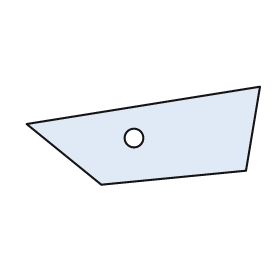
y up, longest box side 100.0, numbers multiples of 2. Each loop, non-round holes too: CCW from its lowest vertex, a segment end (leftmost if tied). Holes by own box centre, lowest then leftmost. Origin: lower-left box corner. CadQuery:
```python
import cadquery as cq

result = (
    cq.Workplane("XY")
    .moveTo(32.0, 0.0)
    .lineTo(94.0, 6.0)
    .lineTo(100.0, 42.0)
    .lineTo(0.0, 26.0)
    .close()
    .moveTo(46.0, 20.0)
    .circle(4.0)
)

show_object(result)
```